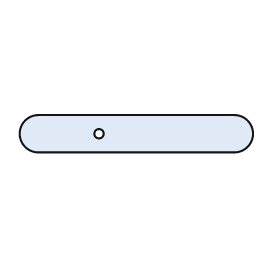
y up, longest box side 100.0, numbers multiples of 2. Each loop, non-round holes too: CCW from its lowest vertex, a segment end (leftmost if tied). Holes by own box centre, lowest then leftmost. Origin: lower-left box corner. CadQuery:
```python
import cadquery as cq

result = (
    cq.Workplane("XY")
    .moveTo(8.0, 0.0)
    .lineTo(92.0, 0.0)
    .threePointArc((100.0, 8.0), (92.0, 16.0))
    .lineTo(8.0, 16.0)
    .threePointArc((0.0, 8.0), (8.0, 0.0))
    .close()
    .moveTo(34.0, 8.0)
    .circle(2.0)
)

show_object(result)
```